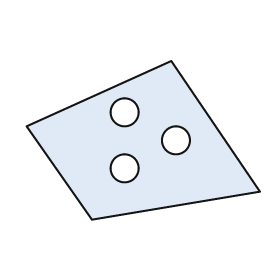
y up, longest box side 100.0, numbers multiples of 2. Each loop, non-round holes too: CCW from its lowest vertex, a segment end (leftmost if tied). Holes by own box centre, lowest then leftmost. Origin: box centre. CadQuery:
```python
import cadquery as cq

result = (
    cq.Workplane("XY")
    .moveTo(-22.0, -34.0)
    .lineTo(50.0, -22.0)
    .lineTo(12.0, 34.0)
    .lineTo(-50.0, 6.0)
    .close()
    .moveTo(-8.0, -12.0)
    .circle(6.0)
    .moveTo(14.0, 0.0)
    .circle(6.0)
    .moveTo(-8.0, 12.0)
    .circle(6.0)
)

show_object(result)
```